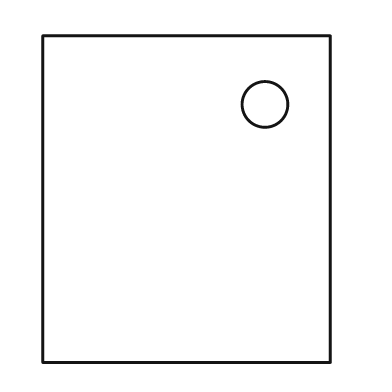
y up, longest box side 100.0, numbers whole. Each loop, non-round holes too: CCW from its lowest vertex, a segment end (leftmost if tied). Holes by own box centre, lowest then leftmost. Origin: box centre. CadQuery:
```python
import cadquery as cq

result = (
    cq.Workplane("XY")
    .moveTo(-44.0, -50.0)
    .lineTo(44.0, -50.0)
    .lineTo(44.0, 50.0)
    .lineTo(-44.0, 50.0)
    .close()
    .moveTo(24.0, 29.0)
    .circle(7.0)
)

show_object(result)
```